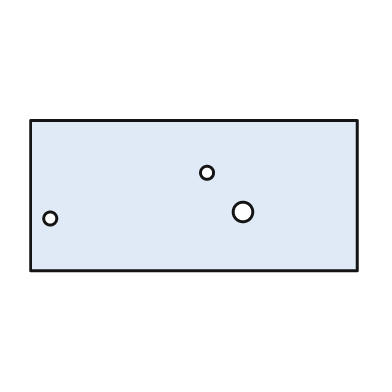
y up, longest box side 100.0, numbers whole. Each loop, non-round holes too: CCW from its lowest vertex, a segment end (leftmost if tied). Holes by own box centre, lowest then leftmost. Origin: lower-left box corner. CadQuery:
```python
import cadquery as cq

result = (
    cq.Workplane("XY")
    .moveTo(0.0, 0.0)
    .lineTo(100.0, 0.0)
    .lineTo(100.0, 46.0)
    .lineTo(0.0, 46.0)
    .close()
    .moveTo(6.0, 16.0)
    .circle(2.0)
    .moveTo(65.0, 18.0)
    .circle(3.0)
    .moveTo(54.0, 30.0)
    .circle(2.0)
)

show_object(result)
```